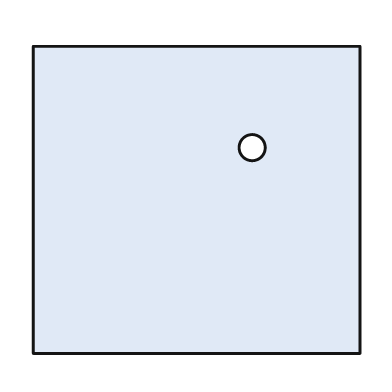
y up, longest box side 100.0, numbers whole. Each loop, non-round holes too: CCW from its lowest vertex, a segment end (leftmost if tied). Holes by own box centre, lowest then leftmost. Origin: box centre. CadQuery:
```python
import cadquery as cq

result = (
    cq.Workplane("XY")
    .moveTo(-50.0, -47.0)
    .lineTo(50.0, -47.0)
    .lineTo(50.0, 47.0)
    .lineTo(-50.0, 47.0)
    .close()
    .moveTo(17.0, 16.0)
    .circle(4.0)
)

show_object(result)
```